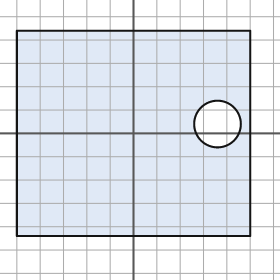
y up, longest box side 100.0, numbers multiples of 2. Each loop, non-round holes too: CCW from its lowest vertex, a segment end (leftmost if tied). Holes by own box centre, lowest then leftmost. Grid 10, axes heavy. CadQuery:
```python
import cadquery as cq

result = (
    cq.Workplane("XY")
    .moveTo(-50.0, -44.0)
    .lineTo(50.0, -44.0)
    .lineTo(50.0, 44.0)
    .lineTo(-50.0, 44.0)
    .close()
    .moveTo(36.0, 4.0)
    .circle(10.0)
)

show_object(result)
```